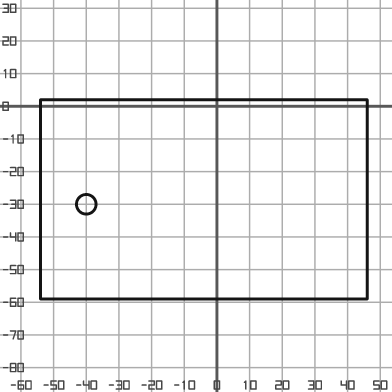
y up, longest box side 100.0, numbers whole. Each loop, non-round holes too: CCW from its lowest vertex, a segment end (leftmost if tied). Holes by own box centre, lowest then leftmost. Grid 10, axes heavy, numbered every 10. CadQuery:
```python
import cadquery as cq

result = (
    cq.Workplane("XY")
    .moveTo(-54.0, -59.0)
    .lineTo(46.0, -59.0)
    .lineTo(46.0, 2.0)
    .lineTo(-54.0, 2.0)
    .close()
    .moveTo(-40.0, -30.0)
    .circle(3.0)
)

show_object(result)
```